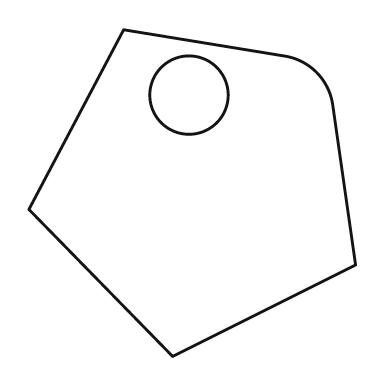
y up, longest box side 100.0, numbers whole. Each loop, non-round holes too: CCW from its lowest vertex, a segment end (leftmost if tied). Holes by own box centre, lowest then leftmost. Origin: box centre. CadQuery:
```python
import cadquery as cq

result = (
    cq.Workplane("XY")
    .moveTo(-6.0, -50.0)
    .lineTo(50.0, -22.0)
    .lineTo(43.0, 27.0)
    .threePointArc((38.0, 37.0), (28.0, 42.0))
    .lineTo(-21.0, 50.0)
    .lineTo(-50.0, -5.0)
    .close()
    .moveTo(-1.0, 30.0)
    .circle(12.0)
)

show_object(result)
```